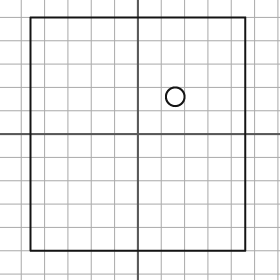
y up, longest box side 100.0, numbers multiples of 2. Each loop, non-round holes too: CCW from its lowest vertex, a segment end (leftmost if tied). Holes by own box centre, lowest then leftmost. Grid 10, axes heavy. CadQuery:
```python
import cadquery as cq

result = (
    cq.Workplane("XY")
    .moveTo(-46.0, -50.0)
    .lineTo(46.0, -50.0)
    .lineTo(46.0, 50.0)
    .lineTo(-46.0, 50.0)
    .close()
    .moveTo(16.0, 16.0)
    .circle(4.0)
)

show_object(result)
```